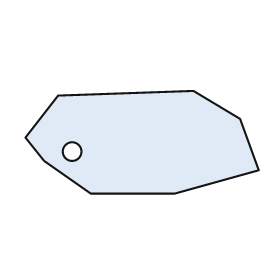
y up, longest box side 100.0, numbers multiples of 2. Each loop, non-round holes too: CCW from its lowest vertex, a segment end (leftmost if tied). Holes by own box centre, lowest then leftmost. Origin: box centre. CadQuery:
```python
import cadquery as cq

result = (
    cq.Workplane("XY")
    .moveTo(-22.0, -22.0)
    .lineTo(14.0, -22.0)
    .lineTo(50.0, -12.0)
    .lineTo(42.0, 10.0)
    .lineTo(22.0, 22.0)
    .lineTo(-36.0, 20.0)
    .lineTo(-50.0, 2.0)
    .lineTo(-42.0, -8.0)
    .close()
    .moveTo(-30.0, -4.0)
    .circle(4.0)
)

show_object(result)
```